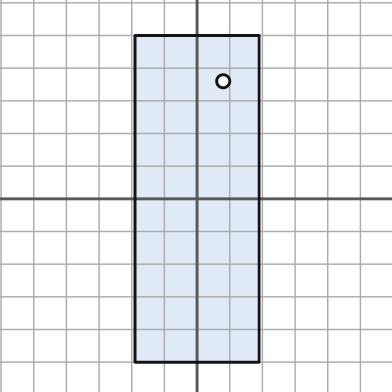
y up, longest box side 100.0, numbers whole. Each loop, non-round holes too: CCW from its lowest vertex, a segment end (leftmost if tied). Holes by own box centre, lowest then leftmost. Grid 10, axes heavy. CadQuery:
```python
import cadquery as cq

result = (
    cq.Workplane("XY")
    .moveTo(-19.0, -50.0)
    .lineTo(19.0, -50.0)
    .lineTo(19.0, 50.0)
    .lineTo(-19.0, 50.0)
    .close()
    .moveTo(8.0, 36.0)
    .circle(2.0)
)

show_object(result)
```